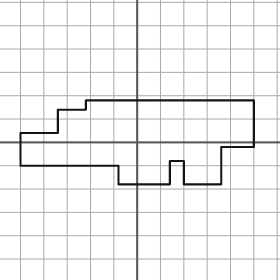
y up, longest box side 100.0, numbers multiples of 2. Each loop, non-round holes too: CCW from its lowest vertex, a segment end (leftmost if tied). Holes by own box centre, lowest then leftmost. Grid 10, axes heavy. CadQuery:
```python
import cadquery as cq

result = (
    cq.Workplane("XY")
    .moveTo(-8.0, -18.0)
    .lineTo(14.0, -18.0)
    .lineTo(14.0, -8.0)
    .lineTo(20.0, -8.0)
    .lineTo(20.0, -18.0)
    .lineTo(36.0, -18.0)
    .lineTo(36.0, -2.0)
    .lineTo(50.0, -2.0)
    .lineTo(50.0, 18.0)
    .lineTo(-22.0, 18.0)
    .lineTo(-22.0, 14.0)
    .lineTo(-34.0, 14.0)
    .lineTo(-34.0, 4.0)
    .lineTo(-50.0, 4.0)
    .lineTo(-50.0, -10.0)
    .lineTo(-8.0, -10.0)
    .close()
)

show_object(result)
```